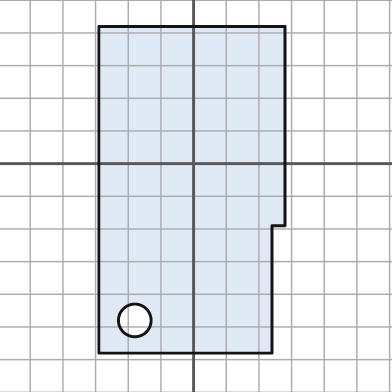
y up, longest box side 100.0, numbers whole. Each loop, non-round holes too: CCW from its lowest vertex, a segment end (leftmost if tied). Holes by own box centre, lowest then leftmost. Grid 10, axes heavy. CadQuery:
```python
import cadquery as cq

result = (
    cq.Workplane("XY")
    .moveTo(-29.0, -58.0)
    .lineTo(24.0, -58.0)
    .lineTo(24.0, -19.0)
    .lineTo(28.0, -19.0)
    .lineTo(28.0, 42.0)
    .lineTo(-29.0, 42.0)
    .close()
    .moveTo(-18.0, -48.0)
    .circle(5.0)
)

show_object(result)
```